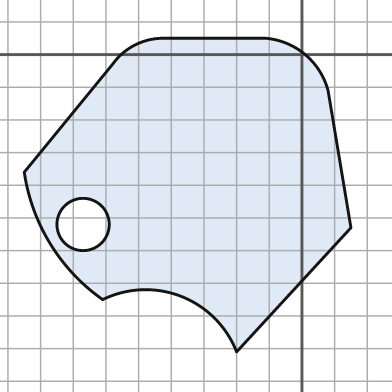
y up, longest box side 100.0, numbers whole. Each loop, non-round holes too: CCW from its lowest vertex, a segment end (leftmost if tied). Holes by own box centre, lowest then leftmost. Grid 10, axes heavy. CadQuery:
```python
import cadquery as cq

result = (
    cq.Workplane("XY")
    .moveTo(-20.0, -91.0)
    .lineTo(15.0, -53.0)
    .lineTo(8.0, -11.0)
    .threePointArc((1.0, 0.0), (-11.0, 5.0))
    .lineTo(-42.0, 5.0)
    .threePointArc((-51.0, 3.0), (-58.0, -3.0))
    .lineTo(-85.0, -36.0)
    .threePointArc((-77.0, -58.0), (-61.0, -75.0))
    .threePointArc((-37.0, -74.0), (-20.0, -91.0))
    .close()
    .moveTo(-67.0, -52.0)
    .circle(8.0)
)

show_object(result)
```